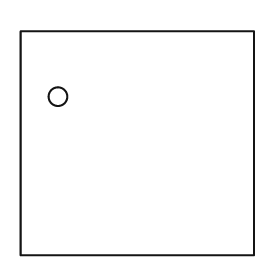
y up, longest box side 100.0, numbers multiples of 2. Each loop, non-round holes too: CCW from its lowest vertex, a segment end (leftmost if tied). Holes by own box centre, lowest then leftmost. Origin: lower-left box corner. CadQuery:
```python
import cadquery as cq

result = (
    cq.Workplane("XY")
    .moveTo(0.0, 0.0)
    .lineTo(100.0, 0.0)
    .lineTo(100.0, 96.0)
    .lineTo(0.0, 96.0)
    .close()
    .moveTo(16.0, 68.0)
    .circle(4.0)
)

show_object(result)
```